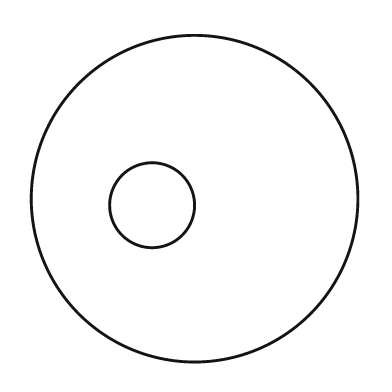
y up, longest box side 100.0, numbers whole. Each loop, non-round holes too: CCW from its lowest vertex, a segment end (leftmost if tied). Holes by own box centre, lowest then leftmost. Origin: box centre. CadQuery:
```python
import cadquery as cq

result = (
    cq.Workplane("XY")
    .moveTo(0.0, 0.0)
    .circle(50.0)
    .moveTo(-13.0, -2.0)
    .circle(13.0)
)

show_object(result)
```